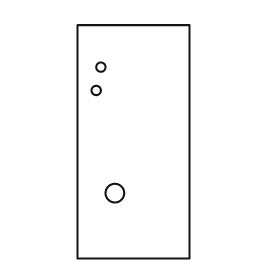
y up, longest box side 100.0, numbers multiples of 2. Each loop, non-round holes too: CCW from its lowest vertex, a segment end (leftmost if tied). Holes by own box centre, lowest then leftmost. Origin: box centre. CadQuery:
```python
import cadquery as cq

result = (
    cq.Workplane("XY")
    .moveTo(-24.0, -50.0)
    .lineTo(24.0, -50.0)
    .lineTo(24.0, 50.0)
    .lineTo(-24.0, 50.0)
    .close()
    .moveTo(-8.0, -22.0)
    .circle(4.0)
    .moveTo(-16.0, 22.0)
    .circle(2.0)
    .moveTo(-14.0, 32.0)
    .circle(2.0)
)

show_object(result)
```